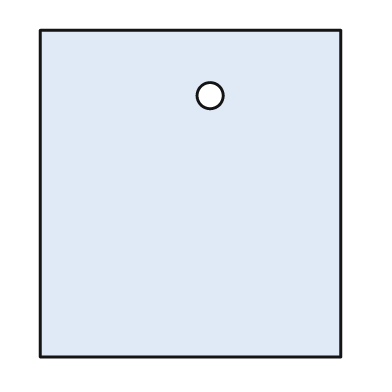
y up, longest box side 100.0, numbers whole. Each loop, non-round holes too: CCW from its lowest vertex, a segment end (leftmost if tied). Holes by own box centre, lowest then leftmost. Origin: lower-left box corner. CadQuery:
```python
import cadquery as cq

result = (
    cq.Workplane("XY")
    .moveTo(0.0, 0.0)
    .lineTo(92.0, 0.0)
    .lineTo(92.0, 100.0)
    .lineTo(0.0, 100.0)
    .close()
    .moveTo(52.0, 80.0)
    .circle(4.0)
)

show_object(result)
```